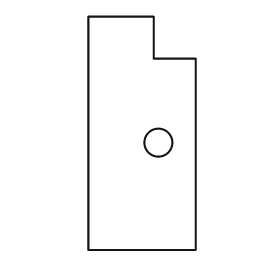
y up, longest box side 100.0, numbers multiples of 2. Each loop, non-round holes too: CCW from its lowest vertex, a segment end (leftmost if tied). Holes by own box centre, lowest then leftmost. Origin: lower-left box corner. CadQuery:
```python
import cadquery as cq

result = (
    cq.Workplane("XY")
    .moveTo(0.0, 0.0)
    .lineTo(46.0, 0.0)
    .lineTo(46.0, 82.0)
    .lineTo(28.0, 82.0)
    .lineTo(28.0, 100.0)
    .lineTo(0.0, 100.0)
    .close()
    .moveTo(30.0, 46.0)
    .circle(6.0)
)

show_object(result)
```